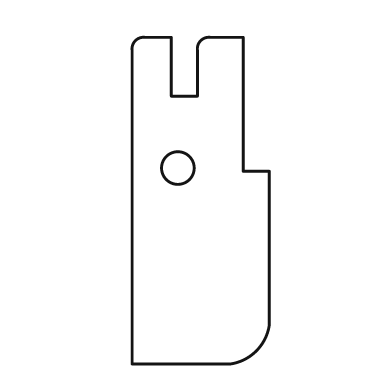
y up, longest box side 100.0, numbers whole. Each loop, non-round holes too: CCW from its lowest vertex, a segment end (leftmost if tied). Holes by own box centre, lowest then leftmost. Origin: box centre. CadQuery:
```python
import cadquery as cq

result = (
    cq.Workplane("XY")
    .moveTo(-21.0, -50.0)
    .lineTo(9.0, -50.0)
    .threePointArc((17.0, -46.0), (21.0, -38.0))
    .lineTo(21.0, 9.0)
    .lineTo(13.0, 9.0)
    .lineTo(13.0, 50.0)
    .lineTo(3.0, 50.0)
    .threePointArc((0.0, 49.0), (-1.0, 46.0))
    .lineTo(-1.0, 32.0)
    .lineTo(-9.0, 32.0)
    .lineTo(-9.0, 50.0)
    .lineTo(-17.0, 50.0)
    .threePointArc((-20.0, 49.0), (-21.0, 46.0))
    .close()
    .moveTo(-7.0, 10.0)
    .circle(5.0)
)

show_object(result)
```